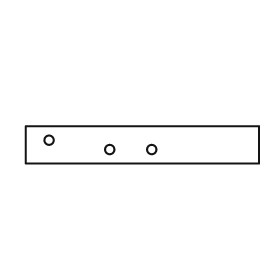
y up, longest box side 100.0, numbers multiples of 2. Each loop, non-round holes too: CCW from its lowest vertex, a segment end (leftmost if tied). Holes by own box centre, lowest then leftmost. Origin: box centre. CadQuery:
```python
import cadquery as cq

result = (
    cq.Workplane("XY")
    .moveTo(-50.0, -8.0)
    .lineTo(50.0, -8.0)
    .lineTo(50.0, 8.0)
    .lineTo(-50.0, 8.0)
    .close()
    .moveTo(-14.0, -2.0)
    .circle(2.0)
    .moveTo(4.0, -2.0)
    .circle(2.0)
    .moveTo(-40.0, 2.0)
    .circle(2.0)
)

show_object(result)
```